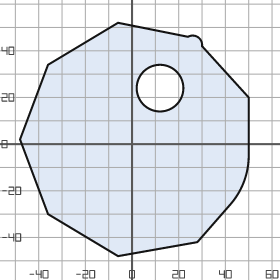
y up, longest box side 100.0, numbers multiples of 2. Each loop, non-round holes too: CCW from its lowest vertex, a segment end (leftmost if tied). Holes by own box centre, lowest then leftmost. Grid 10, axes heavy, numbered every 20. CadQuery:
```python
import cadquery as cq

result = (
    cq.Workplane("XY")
    .moveTo(-6.0, -48.0)
    .lineTo(28.0, -42.0)
    .lineTo(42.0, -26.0)
    .threePointArc((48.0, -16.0), (50.0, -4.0))
    .lineTo(50.0, 20.0)
    .lineTo(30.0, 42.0)
    .threePointArc((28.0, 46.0), (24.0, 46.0))
    .lineTo(-6.0, 52.0)
    .lineTo(-36.0, 34.0)
    .lineTo(-48.0, 2.0)
    .lineTo(-36.0, -30.0)
    .close()
    .moveTo(12.0, 24.0)
    .circle(10.0)
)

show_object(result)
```